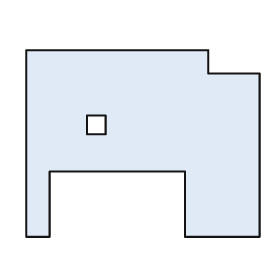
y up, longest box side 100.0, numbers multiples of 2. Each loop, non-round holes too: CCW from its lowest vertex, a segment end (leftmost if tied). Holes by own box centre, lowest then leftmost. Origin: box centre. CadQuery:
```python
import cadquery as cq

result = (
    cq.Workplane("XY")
    .moveTo(-50.0, -40.0)
    .lineTo(-40.0, -40.0)
    .lineTo(-40.0, -12.0)
    .lineTo(18.0, -12.0)
    .lineTo(18.0, -40.0)
    .lineTo(50.0, -40.0)
    .lineTo(50.0, 30.0)
    .lineTo(28.0, 30.0)
    .lineTo(28.0, 40.0)
    .lineTo(-50.0, 40.0)
    .close()
    .moveTo(-24.0, 4.0)
    .lineTo(-16.0, 4.0)
    .lineTo(-16.0, 12.0)
    .lineTo(-24.0, 12.0)
    .close()
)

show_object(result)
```